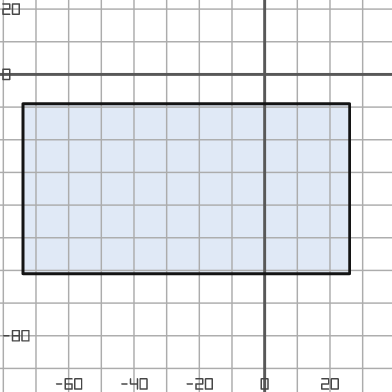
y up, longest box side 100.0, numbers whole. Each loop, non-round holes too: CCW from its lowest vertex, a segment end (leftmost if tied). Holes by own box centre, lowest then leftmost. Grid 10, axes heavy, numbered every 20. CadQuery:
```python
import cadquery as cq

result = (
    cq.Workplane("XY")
    .moveTo(-74.0, -61.0)
    .lineTo(26.0, -61.0)
    .lineTo(26.0, -9.0)
    .lineTo(-74.0, -9.0)
    .close()
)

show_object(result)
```